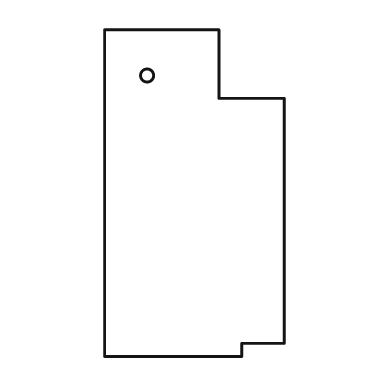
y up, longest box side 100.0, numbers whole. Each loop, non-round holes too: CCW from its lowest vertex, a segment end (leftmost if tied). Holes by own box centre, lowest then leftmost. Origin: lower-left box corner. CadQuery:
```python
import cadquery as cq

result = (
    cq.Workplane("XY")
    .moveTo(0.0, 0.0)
    .lineTo(42.0, 0.0)
    .lineTo(42.0, 4.0)
    .lineTo(55.0, 4.0)
    .lineTo(55.0, 79.0)
    .lineTo(35.0, 79.0)
    .lineTo(35.0, 100.0)
    .lineTo(0.0, 100.0)
    .close()
    .moveTo(13.0, 86.0)
    .circle(2.0)
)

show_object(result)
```